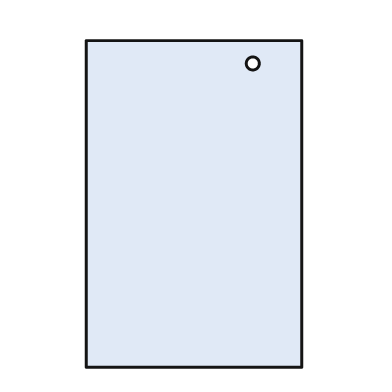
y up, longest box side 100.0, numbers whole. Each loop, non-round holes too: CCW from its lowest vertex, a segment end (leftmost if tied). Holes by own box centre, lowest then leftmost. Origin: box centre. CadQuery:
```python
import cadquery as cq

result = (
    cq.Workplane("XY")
    .moveTo(-33.0, -50.0)
    .lineTo(33.0, -50.0)
    .lineTo(33.0, 50.0)
    .lineTo(-33.0, 50.0)
    .close()
    .moveTo(18.0, 43.0)
    .circle(2.0)
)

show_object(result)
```